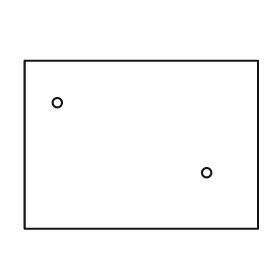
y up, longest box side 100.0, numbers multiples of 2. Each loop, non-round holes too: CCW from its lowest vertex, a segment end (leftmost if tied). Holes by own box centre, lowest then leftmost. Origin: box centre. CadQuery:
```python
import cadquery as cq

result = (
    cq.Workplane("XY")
    .moveTo(-50.0, -36.0)
    .lineTo(50.0, -36.0)
    .lineTo(50.0, 36.0)
    .lineTo(-50.0, 36.0)
    .close()
    .moveTo(28.0, -12.0)
    .circle(2.0)
    .moveTo(-36.0, 18.0)
    .circle(2.0)
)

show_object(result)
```